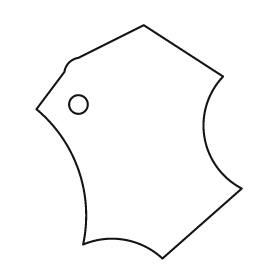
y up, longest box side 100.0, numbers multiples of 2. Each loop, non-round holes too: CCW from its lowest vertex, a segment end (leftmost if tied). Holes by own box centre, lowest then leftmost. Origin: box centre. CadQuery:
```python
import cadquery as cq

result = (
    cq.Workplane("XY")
    .moveTo(10.0, -50.0)
    .lineTo(44.0, -20.0)
    .threePointArc((28.0, 2.0), (36.0, 28.0))
    .lineTo(2.0, 50.0)
    .lineTo(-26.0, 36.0)
    .threePointArc((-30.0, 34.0), (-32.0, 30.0))
    .lineTo(-44.0, 14.0)
    .threePointArc((-26.0, -12.0), (-24.0, -44.0))
    .threePointArc((-6.0, -42.0), (10.0, -50.0))
    .close()
    .moveTo(-26.0, 16.0)
    .circle(4.0)
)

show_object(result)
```